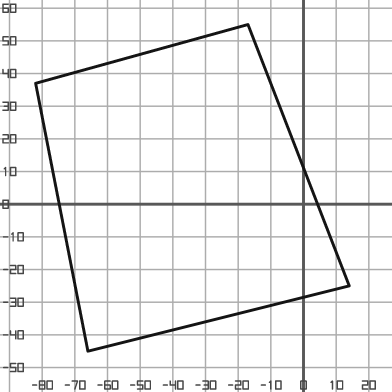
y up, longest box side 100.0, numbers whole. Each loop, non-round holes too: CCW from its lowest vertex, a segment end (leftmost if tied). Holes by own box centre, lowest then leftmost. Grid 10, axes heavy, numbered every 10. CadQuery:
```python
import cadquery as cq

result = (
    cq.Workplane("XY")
    .moveTo(-66.0, -45.0)
    .lineTo(14.0, -25.0)
    .lineTo(-17.0, 55.0)
    .lineTo(-82.0, 37.0)
    .close()
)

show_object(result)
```